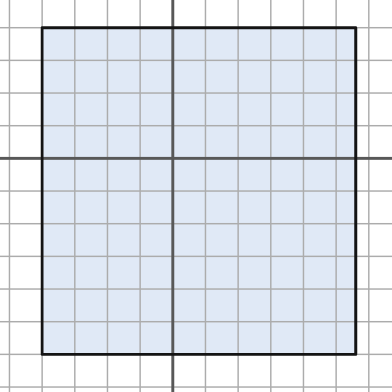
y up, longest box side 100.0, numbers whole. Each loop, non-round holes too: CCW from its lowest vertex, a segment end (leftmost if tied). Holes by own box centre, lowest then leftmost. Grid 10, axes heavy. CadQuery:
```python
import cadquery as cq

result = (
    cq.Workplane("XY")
    .moveTo(-40.0, -60.0)
    .lineTo(56.0, -60.0)
    .lineTo(56.0, 40.0)
    .lineTo(-40.0, 40.0)
    .close()
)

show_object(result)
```